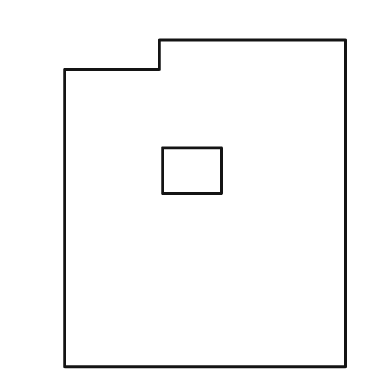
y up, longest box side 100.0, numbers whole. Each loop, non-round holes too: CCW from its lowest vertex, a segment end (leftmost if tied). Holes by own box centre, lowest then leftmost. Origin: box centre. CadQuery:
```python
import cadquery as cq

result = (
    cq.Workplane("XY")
    .moveTo(-43.0, -50.0)
    .lineTo(43.0, -50.0)
    .lineTo(43.0, 50.0)
    .lineTo(-14.0, 50.0)
    .lineTo(-14.0, 41.0)
    .lineTo(-43.0, 41.0)
    .close()
    .moveTo(-13.0, 3.0)
    .lineTo(5.0, 3.0)
    .lineTo(5.0, 17.0)
    .lineTo(-13.0, 17.0)
    .close()
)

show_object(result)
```